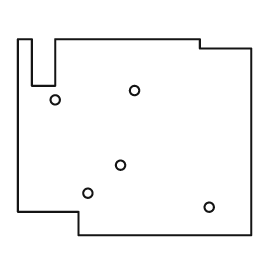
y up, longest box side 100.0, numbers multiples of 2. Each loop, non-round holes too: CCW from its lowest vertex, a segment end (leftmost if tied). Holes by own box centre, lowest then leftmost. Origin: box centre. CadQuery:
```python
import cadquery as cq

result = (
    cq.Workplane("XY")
    .moveTo(-24.0, -42.0)
    .lineTo(50.0, -42.0)
    .lineTo(50.0, 38.0)
    .lineTo(28.0, 38.0)
    .lineTo(28.0, 42.0)
    .lineTo(-34.0, 42.0)
    .lineTo(-34.0, 22.0)
    .lineTo(-44.0, 22.0)
    .lineTo(-44.0, 42.0)
    .lineTo(-50.0, 42.0)
    .lineTo(-50.0, -32.0)
    .lineTo(-24.0, -32.0)
    .close()
    .moveTo(32.0, -30.0)
    .circle(2.0)
    .moveTo(-20.0, -24.0)
    .circle(2.0)
    .moveTo(-6.0, -12.0)
    .circle(2.0)
    .moveTo(-34.0, 16.0)
    .circle(2.0)
    .moveTo(0.0, 20.0)
    .circle(2.0)
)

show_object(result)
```